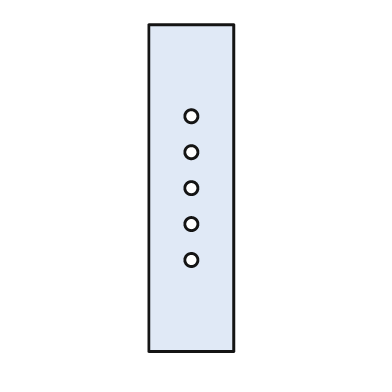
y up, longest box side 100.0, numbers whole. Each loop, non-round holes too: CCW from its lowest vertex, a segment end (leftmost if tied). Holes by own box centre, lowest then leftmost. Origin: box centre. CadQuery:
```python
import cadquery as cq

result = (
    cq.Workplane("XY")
    .moveTo(-13.0, -50.0)
    .lineTo(13.0, -50.0)
    .lineTo(13.0, 50.0)
    .lineTo(-13.0, 50.0)
    .close()
    .moveTo(0.0, -22.0)
    .circle(2.0)
    .moveTo(0.0, -11.0)
    .circle(2.0)
    .moveTo(0.0, 0.0)
    .circle(2.0)
    .moveTo(0.0, 11.0)
    .circle(2.0)
    .moveTo(0.0, 22.0)
    .circle(2.0)
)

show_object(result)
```